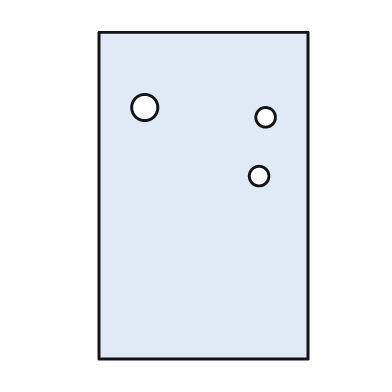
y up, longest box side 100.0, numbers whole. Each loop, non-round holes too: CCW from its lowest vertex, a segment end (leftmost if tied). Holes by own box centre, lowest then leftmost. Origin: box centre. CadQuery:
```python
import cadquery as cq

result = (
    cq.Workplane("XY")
    .moveTo(-32.0, -50.0)
    .lineTo(32.0, -50.0)
    .lineTo(32.0, 50.0)
    .lineTo(-32.0, 50.0)
    .close()
    .moveTo(17.0, 6.0)
    .circle(3.0)
    .moveTo(19.0, 24.0)
    .circle(3.0)
    .moveTo(-18.0, 27.0)
    .circle(4.0)
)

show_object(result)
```